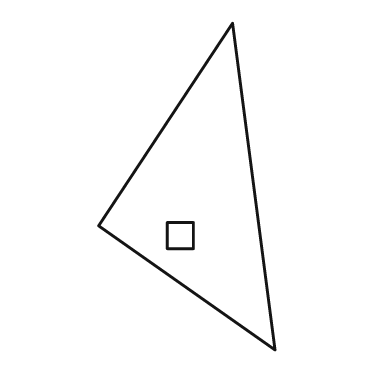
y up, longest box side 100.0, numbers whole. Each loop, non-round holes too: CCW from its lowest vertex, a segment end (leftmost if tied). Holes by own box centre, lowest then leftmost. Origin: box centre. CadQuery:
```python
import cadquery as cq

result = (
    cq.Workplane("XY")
    .moveTo(27.0, -50.0)
    .lineTo(14.0, 50.0)
    .lineTo(-27.0, -12.0)
    .close()
    .moveTo(-6.0, -19.0)
    .lineTo(2.0, -19.0)
    .lineTo(2.0, -11.0)
    .lineTo(-6.0, -11.0)
    .close()
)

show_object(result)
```